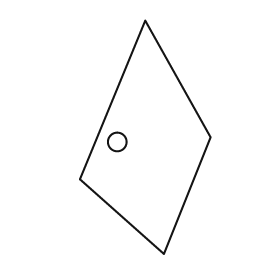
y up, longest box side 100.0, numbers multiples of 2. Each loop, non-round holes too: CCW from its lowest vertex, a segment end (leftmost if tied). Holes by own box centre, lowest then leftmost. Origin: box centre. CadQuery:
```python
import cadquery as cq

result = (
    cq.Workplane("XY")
    .moveTo(8.0, -50.0)
    .lineTo(28.0, 0.0)
    .lineTo(0.0, 50.0)
    .lineTo(-28.0, -18.0)
    .close()
    .moveTo(-12.0, -2.0)
    .circle(4.0)
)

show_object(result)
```